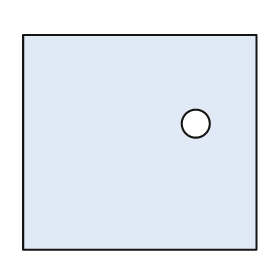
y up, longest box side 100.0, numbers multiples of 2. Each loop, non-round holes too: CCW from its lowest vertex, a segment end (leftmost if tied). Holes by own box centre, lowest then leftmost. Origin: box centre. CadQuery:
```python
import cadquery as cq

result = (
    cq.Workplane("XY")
    .moveTo(-50.0, -46.0)
    .lineTo(50.0, -46.0)
    .lineTo(50.0, 46.0)
    .lineTo(-50.0, 46.0)
    .close()
    .moveTo(24.0, 8.0)
    .circle(6.0)
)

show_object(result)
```